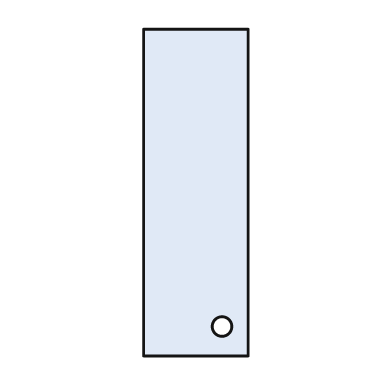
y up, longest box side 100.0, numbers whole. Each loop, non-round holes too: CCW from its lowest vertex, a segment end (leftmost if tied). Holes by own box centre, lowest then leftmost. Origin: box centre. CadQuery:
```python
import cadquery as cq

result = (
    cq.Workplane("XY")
    .moveTo(-16.0, -50.0)
    .lineTo(16.0, -50.0)
    .lineTo(16.0, 50.0)
    .lineTo(-16.0, 50.0)
    .close()
    .moveTo(8.0, -41.0)
    .circle(3.0)
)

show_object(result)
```